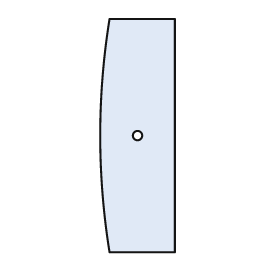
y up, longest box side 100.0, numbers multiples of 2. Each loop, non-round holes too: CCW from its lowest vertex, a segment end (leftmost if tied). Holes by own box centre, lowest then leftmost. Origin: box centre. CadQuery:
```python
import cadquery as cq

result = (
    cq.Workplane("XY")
    .moveTo(-12.0, -50.0)
    .lineTo(16.0, -50.0)
    .lineTo(16.0, 50.0)
    .lineTo(-12.0, 50.0)
    .threePointArc((-16.0, 0.0), (-12.0, -50.0))
    .close()
    .moveTo(0.0, 0.0)
    .circle(2.0)
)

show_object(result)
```